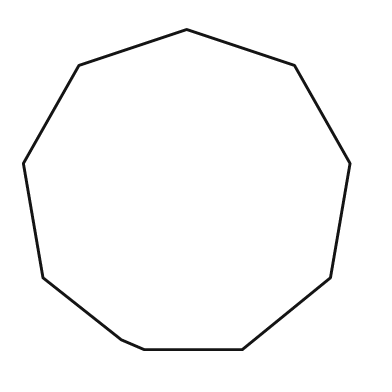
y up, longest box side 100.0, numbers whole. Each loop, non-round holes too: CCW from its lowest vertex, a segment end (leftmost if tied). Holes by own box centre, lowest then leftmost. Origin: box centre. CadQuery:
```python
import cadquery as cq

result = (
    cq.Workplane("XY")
    .moveTo(-13.0, -49.0)
    .lineTo(17.0, -49.0)
    .lineTo(44.0, -27.0)
    .lineTo(50.0, 8.0)
    .lineTo(33.0, 38.0)
    .lineTo(0.0, 49.0)
    .lineTo(-33.0, 38.0)
    .lineTo(-50.0, 8.0)
    .lineTo(-44.0, -27.0)
    .lineTo(-20.0, -46.0)
    .close()
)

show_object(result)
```